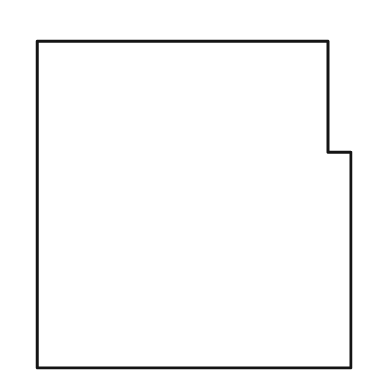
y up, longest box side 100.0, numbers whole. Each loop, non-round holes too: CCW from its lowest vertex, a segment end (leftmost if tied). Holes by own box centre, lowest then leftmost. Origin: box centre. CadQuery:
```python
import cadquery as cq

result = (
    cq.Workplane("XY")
    .moveTo(-48.0, -50.0)
    .lineTo(48.0, -50.0)
    .lineTo(48.0, 16.0)
    .lineTo(41.0, 16.0)
    .lineTo(41.0, 50.0)
    .lineTo(-48.0, 50.0)
    .close()
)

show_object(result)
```